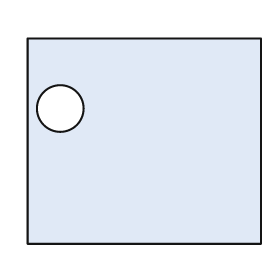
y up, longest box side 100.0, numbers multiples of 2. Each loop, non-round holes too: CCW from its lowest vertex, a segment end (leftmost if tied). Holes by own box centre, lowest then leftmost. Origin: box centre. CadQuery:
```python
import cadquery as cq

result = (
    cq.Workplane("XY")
    .moveTo(-50.0, -44.0)
    .lineTo(50.0, -44.0)
    .lineTo(50.0, 44.0)
    .lineTo(-50.0, 44.0)
    .close()
    .moveTo(-36.0, 14.0)
    .circle(10.0)
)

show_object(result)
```